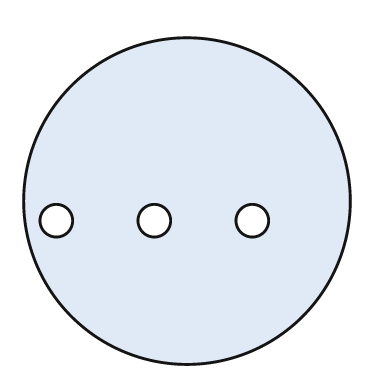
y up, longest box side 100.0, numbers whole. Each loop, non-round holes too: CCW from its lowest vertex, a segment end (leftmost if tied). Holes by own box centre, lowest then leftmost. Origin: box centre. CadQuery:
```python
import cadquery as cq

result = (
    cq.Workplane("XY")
    .moveTo(0.0, 0.0)
    .circle(50.0)
    .moveTo(-40.0, -6.0)
    .circle(5.0)
    .moveTo(-10.0, -6.0)
    .circle(5.0)
    .moveTo(20.0, -6.0)
    .circle(5.0)
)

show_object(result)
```